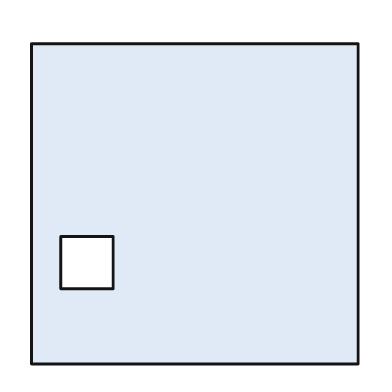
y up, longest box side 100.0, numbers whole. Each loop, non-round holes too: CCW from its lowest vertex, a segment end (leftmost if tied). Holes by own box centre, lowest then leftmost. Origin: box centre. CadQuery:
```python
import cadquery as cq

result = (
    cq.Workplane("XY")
    .moveTo(-50.0, -49.0)
    .lineTo(50.0, -49.0)
    .lineTo(50.0, 49.0)
    .lineTo(-50.0, 49.0)
    .close()
    .moveTo(-41.0, -26.0)
    .lineTo(-25.0, -26.0)
    .lineTo(-25.0, -10.0)
    .lineTo(-41.0, -10.0)
    .close()
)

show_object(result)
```